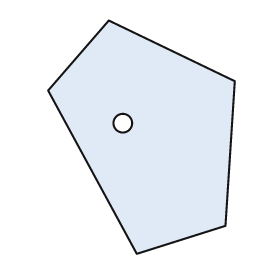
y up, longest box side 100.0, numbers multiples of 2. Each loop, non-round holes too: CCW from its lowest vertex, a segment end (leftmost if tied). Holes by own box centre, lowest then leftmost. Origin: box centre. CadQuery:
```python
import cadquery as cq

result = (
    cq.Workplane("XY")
    .moveTo(-2.0, -50.0)
    .lineTo(36.0, -38.0)
    .lineTo(40.0, 24.0)
    .lineTo(-14.0, 50.0)
    .lineTo(-40.0, 20.0)
    .close()
    .moveTo(-8.0, 6.0)
    .circle(4.0)
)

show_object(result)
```